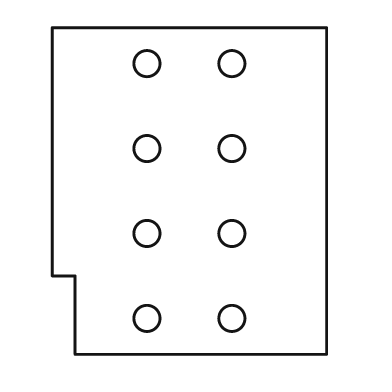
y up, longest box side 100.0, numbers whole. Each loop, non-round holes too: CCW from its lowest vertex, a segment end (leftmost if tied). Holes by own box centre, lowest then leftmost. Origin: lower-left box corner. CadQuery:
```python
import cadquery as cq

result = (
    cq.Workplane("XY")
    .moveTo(7.0, 0.0)
    .lineTo(84.0, 0.0)
    .lineTo(84.0, 100.0)
    .lineTo(0.0, 100.0)
    .lineTo(0.0, 24.0)
    .lineTo(7.0, 24.0)
    .close()
    .moveTo(29.0, 11.0)
    .circle(4.0)
    .moveTo(55.0, 11.0)
    .circle(4.0)
    .moveTo(29.0, 37.0)
    .circle(4.0)
    .moveTo(55.0, 37.0)
    .circle(4.0)
    .moveTo(29.0, 63.0)
    .circle(4.0)
    .moveTo(55.0, 63.0)
    .circle(4.0)
    .moveTo(29.0, 89.0)
    .circle(4.0)
    .moveTo(55.0, 89.0)
    .circle(4.0)
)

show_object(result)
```